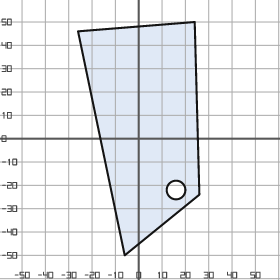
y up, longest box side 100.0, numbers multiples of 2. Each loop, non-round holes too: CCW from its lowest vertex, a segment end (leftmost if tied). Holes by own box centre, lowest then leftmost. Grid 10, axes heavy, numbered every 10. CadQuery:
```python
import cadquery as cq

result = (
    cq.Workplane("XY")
    .moveTo(-6.0, -50.0)
    .lineTo(26.0, -24.0)
    .lineTo(24.0, 50.0)
    .lineTo(-26.0, 46.0)
    .close()
    .moveTo(16.0, -22.0)
    .circle(4.0)
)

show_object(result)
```